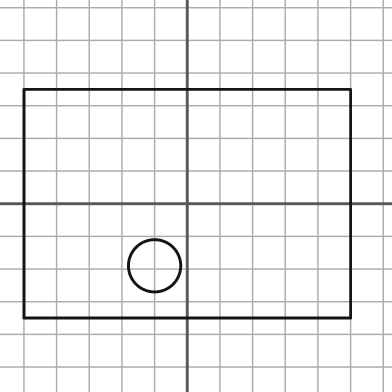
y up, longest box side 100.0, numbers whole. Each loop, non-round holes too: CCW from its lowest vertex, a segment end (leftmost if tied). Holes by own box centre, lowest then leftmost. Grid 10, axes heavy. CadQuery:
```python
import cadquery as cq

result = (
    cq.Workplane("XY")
    .moveTo(-50.0, -35.0)
    .lineTo(50.0, -35.0)
    .lineTo(50.0, 35.0)
    .lineTo(-50.0, 35.0)
    .close()
    .moveTo(-10.0, -19.0)
    .circle(8.0)
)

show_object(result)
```